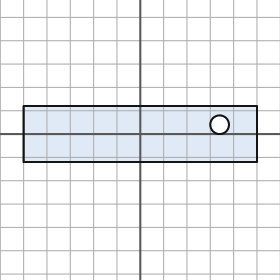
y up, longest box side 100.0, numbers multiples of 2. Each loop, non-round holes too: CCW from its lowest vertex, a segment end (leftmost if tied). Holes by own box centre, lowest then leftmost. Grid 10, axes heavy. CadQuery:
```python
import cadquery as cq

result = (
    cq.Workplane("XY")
    .moveTo(-50.0, -12.0)
    .lineTo(50.0, -12.0)
    .lineTo(50.0, 12.0)
    .lineTo(-50.0, 12.0)
    .close()
    .moveTo(34.0, 4.0)
    .circle(4.0)
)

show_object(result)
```